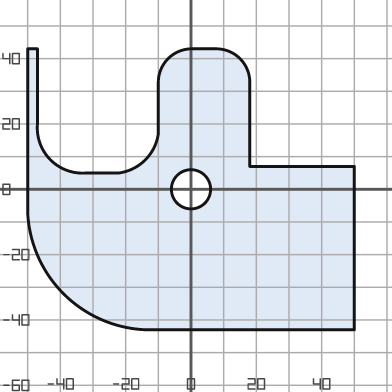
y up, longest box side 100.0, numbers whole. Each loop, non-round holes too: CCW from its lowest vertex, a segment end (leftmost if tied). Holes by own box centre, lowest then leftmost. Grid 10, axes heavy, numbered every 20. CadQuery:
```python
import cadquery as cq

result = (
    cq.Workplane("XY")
    .moveTo(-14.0, -43.0)
    .lineTo(50.0, -43.0)
    .lineTo(50.0, 7.0)
    .lineTo(18.0, 7.0)
    .lineTo(18.0, 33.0)
    .threePointArc((15.0, 40.0), (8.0, 43.0))
    .lineTo(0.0, 43.0)
    .threePointArc((-7.0, 40.0), (-10.0, 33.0))
    .lineTo(-10.0, 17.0)
    .threePointArc((-14.0, 9.0), (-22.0, 5.0))
    .lineTo(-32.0, 5.0)
    .threePointArc((-43.0, 9.0), (-47.0, 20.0))
    .lineTo(-47.0, 43.0)
    .lineTo(-50.0, 43.0)
    .lineTo(-50.0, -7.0)
    .threePointArc((-39.0, -32.0), (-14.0, -43.0))
    .close()
    .moveTo(0.0, 0.0)
    .circle(6.0)
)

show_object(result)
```